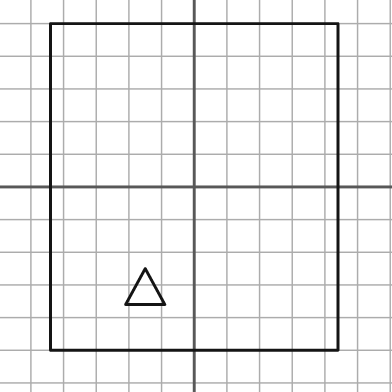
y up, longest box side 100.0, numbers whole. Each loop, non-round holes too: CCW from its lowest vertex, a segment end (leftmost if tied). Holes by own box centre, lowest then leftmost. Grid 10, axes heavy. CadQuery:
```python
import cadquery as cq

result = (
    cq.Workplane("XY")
    .moveTo(-44.0, -50.0)
    .lineTo(44.0, -50.0)
    .lineTo(44.0, 50.0)
    .lineTo(-44.0, 50.0)
    .close()
    .moveTo(-21.0, -36.0)
    .lineTo(-9.0, -36.0)
    .lineTo(-15.0, -25.0)
    .close()
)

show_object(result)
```